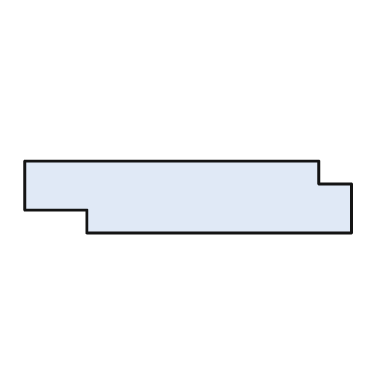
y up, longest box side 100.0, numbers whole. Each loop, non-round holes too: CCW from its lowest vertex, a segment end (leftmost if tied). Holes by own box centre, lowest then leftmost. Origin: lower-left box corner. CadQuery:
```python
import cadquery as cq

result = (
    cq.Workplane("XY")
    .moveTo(19.0, 0.0)
    .lineTo(100.0, 0.0)
    .lineTo(100.0, 15.0)
    .lineTo(90.0, 15.0)
    .lineTo(90.0, 22.0)
    .lineTo(0.0, 22.0)
    .lineTo(0.0, 7.0)
    .lineTo(19.0, 7.0)
    .close()
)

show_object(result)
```